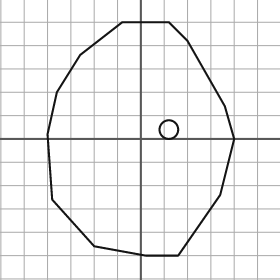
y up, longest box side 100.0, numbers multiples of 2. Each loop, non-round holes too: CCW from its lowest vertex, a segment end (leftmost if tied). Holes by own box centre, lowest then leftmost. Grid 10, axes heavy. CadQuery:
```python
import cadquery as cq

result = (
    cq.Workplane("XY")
    .moveTo(2.0, -50.0)
    .lineTo(16.0, -50.0)
    .lineTo(34.0, -24.0)
    .lineTo(40.0, 0.0)
    .lineTo(36.0, 14.0)
    .lineTo(20.0, 42.0)
    .lineTo(12.0, 50.0)
    .lineTo(-8.0, 50.0)
    .lineTo(-26.0, 36.0)
    .lineTo(-36.0, 20.0)
    .lineTo(-40.0, 2.0)
    .lineTo(-38.0, -26.0)
    .lineTo(-20.0, -46.0)
    .close()
    .moveTo(12.0, 4.0)
    .circle(4.0)
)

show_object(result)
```